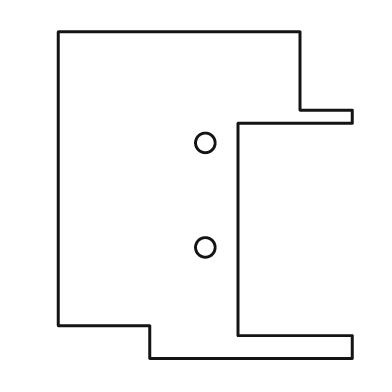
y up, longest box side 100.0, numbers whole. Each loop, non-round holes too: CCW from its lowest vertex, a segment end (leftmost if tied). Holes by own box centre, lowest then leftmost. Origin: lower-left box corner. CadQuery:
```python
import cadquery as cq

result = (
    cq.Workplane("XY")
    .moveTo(28.0, 0.0)
    .lineTo(90.0, 0.0)
    .lineTo(90.0, 7.0)
    .lineTo(55.0, 7.0)
    .lineTo(55.0, 72.0)
    .lineTo(90.0, 72.0)
    .lineTo(90.0, 76.0)
    .lineTo(74.0, 76.0)
    .lineTo(74.0, 100.0)
    .lineTo(0.0, 100.0)
    .lineTo(0.0, 10.0)
    .lineTo(28.0, 10.0)
    .close()
    .moveTo(45.0, 34.0)
    .circle(3.0)
    .moveTo(45.0, 66.0)
    .circle(3.0)
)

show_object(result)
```